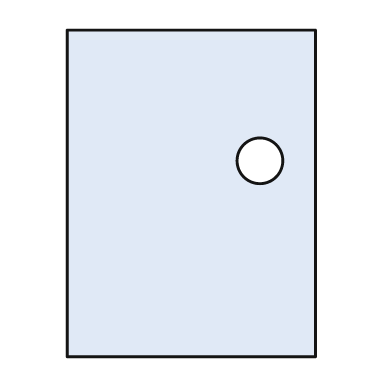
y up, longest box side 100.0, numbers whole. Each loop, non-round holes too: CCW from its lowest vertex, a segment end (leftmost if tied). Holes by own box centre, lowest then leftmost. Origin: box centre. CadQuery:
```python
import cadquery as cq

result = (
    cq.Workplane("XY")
    .moveTo(-38.0, -50.0)
    .lineTo(38.0, -50.0)
    .lineTo(38.0, 50.0)
    .lineTo(-38.0, 50.0)
    .close()
    .moveTo(21.0, 10.0)
    .circle(7.0)
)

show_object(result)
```